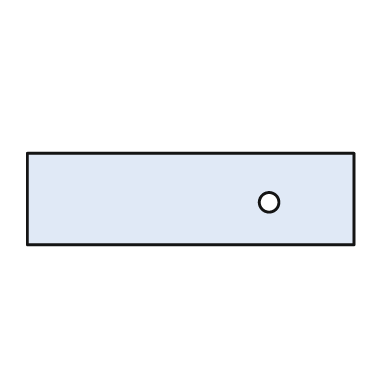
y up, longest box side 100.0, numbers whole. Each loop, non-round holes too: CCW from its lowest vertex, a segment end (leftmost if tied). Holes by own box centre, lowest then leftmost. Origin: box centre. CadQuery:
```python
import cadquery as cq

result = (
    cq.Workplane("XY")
    .moveTo(-50.0, -14.0)
    .lineTo(50.0, -14.0)
    .lineTo(50.0, 14.0)
    .lineTo(-50.0, 14.0)
    .close()
    .moveTo(24.0, -1.0)
    .circle(3.0)
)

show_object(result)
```